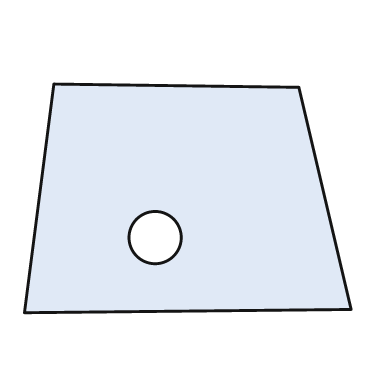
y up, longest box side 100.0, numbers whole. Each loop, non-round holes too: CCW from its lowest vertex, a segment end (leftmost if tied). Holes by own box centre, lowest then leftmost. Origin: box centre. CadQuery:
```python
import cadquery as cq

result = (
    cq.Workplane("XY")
    .moveTo(-50.0, -35.0)
    .lineTo(50.0, -34.0)
    .lineTo(34.0, 34.0)
    .lineTo(-41.0, 35.0)
    .close()
    .moveTo(-10.0, -12.0)
    .circle(8.0)
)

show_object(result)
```